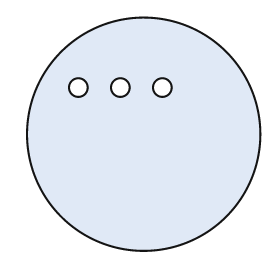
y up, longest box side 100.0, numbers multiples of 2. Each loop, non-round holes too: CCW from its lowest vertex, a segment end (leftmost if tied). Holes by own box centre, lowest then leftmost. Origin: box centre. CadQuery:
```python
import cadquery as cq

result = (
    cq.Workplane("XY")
    .moveTo(0.0, 0.0)
    .circle(50.0)
    .moveTo(-28.0, 20.0)
    .circle(4.0)
    .moveTo(-10.0, 20.0)
    .circle(4.0)
    .moveTo(8.0, 20.0)
    .circle(4.0)
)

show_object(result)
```